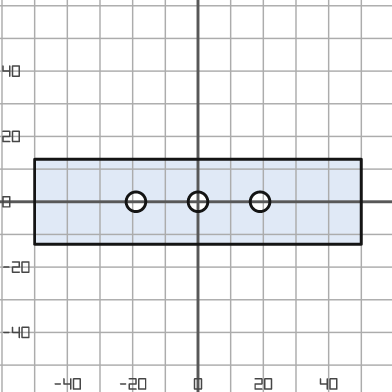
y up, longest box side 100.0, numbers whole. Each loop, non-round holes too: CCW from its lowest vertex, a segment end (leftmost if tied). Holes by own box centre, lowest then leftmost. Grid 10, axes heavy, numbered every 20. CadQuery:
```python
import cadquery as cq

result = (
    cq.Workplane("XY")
    .moveTo(-50.0, -13.0)
    .lineTo(50.0, -13.0)
    .lineTo(50.0, 13.0)
    .lineTo(-50.0, 13.0)
    .close()
    .moveTo(-19.0, 0.0)
    .circle(3.0)
    .moveTo(0.0, 0.0)
    .circle(3.0)
    .moveTo(19.0, 0.0)
    .circle(3.0)
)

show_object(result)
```